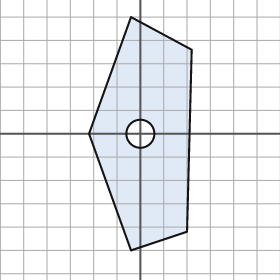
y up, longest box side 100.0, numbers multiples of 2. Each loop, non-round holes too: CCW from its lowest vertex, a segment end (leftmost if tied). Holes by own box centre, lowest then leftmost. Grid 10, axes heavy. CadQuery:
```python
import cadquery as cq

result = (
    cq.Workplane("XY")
    .moveTo(-4.0, -50.0)
    .lineTo(20.0, -42.0)
    .lineTo(22.0, 36.0)
    .lineTo(-4.0, 50.0)
    .lineTo(-22.0, 0.0)
    .close()
    .moveTo(0.0, 0.0)
    .circle(6.0)
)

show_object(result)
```